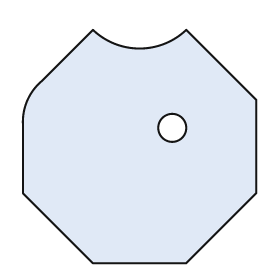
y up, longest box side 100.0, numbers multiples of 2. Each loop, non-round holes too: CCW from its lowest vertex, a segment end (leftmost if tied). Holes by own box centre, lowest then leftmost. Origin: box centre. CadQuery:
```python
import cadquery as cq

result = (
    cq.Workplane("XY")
    .moveTo(-20.0, -50.0)
    .lineTo(20.0, -50.0)
    .lineTo(50.0, -20.0)
    .lineTo(50.0, 20.0)
    .lineTo(20.0, 50.0)
    .threePointArc((0.0, 42.0), (-20.0, 50.0))
    .lineTo(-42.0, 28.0)
    .threePointArc((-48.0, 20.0), (-50.0, 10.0))
    .lineTo(-50.0, -20.0)
    .close()
    .moveTo(14.0, 8.0)
    .circle(6.0)
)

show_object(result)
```